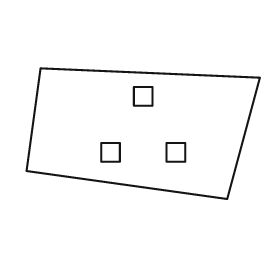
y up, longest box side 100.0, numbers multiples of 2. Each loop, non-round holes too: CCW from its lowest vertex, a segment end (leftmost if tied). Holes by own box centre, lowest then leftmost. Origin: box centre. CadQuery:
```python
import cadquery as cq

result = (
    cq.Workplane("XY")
    .moveTo(36.0, -28.0)
    .lineTo(50.0, 24.0)
    .lineTo(-44.0, 28.0)
    .lineTo(-50.0, -16.0)
    .close()
    .moveTo(-18.0, -12.0)
    .lineTo(-10.0, -12.0)
    .lineTo(-10.0, -4.0)
    .lineTo(-18.0, -4.0)
    .close()
    .moveTo(10.0, -12.0)
    .lineTo(18.0, -12.0)
    .lineTo(18.0, -4.0)
    .lineTo(10.0, -4.0)
    .close()
    .moveTo(-4.0, 12.0)
    .lineTo(4.0, 12.0)
    .lineTo(4.0, 20.0)
    .lineTo(-4.0, 20.0)
    .close()
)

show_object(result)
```